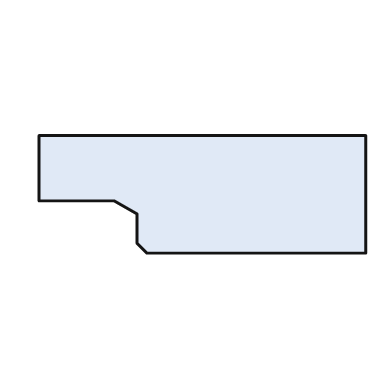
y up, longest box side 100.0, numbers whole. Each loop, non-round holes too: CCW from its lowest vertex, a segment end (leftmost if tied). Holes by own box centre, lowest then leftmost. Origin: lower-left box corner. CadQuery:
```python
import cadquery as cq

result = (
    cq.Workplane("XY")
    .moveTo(33.0, 0.0)
    .lineTo(100.0, 0.0)
    .lineTo(100.0, 36.0)
    .lineTo(0.0, 36.0)
    .lineTo(0.0, 16.0)
    .lineTo(23.0, 16.0)
    .lineTo(30.0, 12.0)
    .lineTo(30.0, 3.0)
    .close()
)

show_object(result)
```